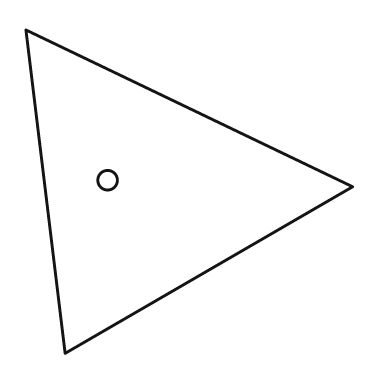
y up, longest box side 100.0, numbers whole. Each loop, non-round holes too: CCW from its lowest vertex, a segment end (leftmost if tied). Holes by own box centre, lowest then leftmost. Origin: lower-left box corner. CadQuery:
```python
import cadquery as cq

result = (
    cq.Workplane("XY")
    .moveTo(12.0, 0.0)
    .lineTo(100.0, 51.0)
    .lineTo(0.0, 99.0)
    .close()
    .moveTo(25.0, 53.0)
    .circle(3.0)
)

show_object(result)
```